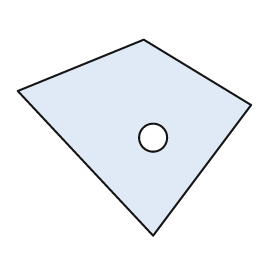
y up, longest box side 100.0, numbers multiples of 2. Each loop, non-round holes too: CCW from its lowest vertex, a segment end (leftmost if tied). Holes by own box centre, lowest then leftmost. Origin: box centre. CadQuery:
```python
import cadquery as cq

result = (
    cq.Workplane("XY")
    .moveTo(8.0, -42.0)
    .lineTo(50.0, 14.0)
    .lineTo(4.0, 42.0)
    .lineTo(-50.0, 20.0)
    .close()
    .moveTo(8.0, 0.0)
    .circle(6.0)
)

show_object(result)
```